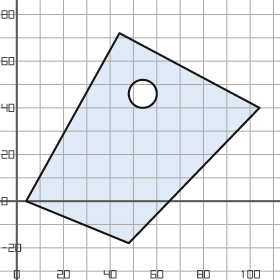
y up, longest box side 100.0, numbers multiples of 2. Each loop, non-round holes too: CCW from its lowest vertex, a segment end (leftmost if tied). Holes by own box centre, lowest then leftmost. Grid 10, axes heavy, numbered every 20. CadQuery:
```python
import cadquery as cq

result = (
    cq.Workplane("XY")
    .moveTo(48.0, -18.0)
    .lineTo(104.0, 40.0)
    .lineTo(44.0, 72.0)
    .lineTo(4.0, 0.0)
    .close()
    .moveTo(54.0, 46.0)
    .circle(6.0)
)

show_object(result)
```